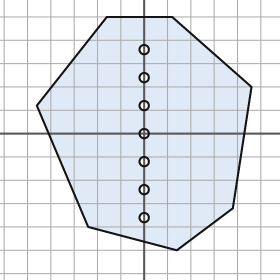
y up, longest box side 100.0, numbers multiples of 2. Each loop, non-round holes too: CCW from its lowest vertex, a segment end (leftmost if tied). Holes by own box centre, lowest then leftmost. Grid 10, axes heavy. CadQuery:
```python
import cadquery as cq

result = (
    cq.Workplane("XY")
    .moveTo(14.0, -50.0)
    .lineTo(38.0, -32.0)
    .lineTo(46.0, 20.0)
    .lineTo(12.0, 50.0)
    .lineTo(-16.0, 50.0)
    .lineTo(-46.0, 12.0)
    .lineTo(-24.0, -40.0)
    .close()
    .moveTo(0.0, -36.0)
    .circle(2.0)
    .moveTo(0.0, -24.0)
    .circle(2.0)
    .moveTo(0.0, -12.0)
    .circle(2.0)
    .moveTo(0.0, 0.0)
    .circle(2.0)
    .moveTo(0.0, 12.0)
    .circle(2.0)
    .moveTo(0.0, 24.0)
    .circle(2.0)
    .moveTo(0.0, 36.0)
    .circle(2.0)
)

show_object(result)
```